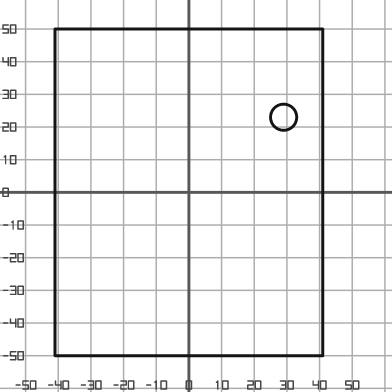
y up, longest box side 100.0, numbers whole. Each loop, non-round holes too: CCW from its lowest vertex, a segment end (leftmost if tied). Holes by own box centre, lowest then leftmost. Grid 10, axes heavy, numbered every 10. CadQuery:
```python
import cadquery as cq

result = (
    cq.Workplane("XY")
    .moveTo(-41.0, -50.0)
    .lineTo(41.0, -50.0)
    .lineTo(41.0, 50.0)
    .lineTo(-41.0, 50.0)
    .close()
    .moveTo(29.0, 23.0)
    .circle(4.0)
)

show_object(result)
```